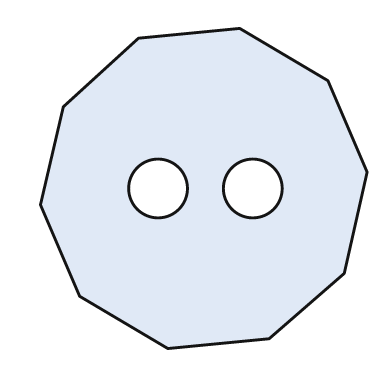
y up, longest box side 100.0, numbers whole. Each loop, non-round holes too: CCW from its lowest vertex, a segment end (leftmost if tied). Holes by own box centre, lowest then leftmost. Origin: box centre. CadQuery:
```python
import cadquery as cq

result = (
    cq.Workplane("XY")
    .moveTo(-11.0, -49.0)
    .lineTo(20.0, -46.0)
    .lineTo(43.0, -26.0)
    .lineTo(50.0, 5.0)
    .lineTo(38.0, 33.0)
    .lineTo(11.0, 49.0)
    .lineTo(-20.0, 46.0)
    .lineTo(-43.0, 25.0)
    .lineTo(-50.0, -5.0)
    .lineTo(-38.0, -33.0)
    .close()
    .moveTo(-14.0, 0.0)
    .circle(9.0)
    .moveTo(15.0, 0.0)
    .circle(9.0)
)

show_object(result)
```